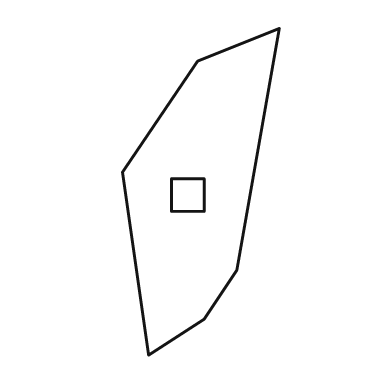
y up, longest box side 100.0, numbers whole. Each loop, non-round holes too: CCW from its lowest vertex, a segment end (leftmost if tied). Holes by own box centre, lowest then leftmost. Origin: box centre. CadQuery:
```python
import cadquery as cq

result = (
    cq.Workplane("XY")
    .moveTo(-16.0, -50.0)
    .lineTo(1.0, -39.0)
    .lineTo(11.0, -24.0)
    .lineTo(24.0, 50.0)
    .lineTo(-1.0, 40.0)
    .lineTo(-24.0, 6.0)
    .close()
    .moveTo(-9.0, -6.0)
    .lineTo(1.0, -6.0)
    .lineTo(1.0, 4.0)
    .lineTo(-9.0, 4.0)
    .close()
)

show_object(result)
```